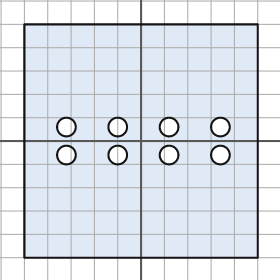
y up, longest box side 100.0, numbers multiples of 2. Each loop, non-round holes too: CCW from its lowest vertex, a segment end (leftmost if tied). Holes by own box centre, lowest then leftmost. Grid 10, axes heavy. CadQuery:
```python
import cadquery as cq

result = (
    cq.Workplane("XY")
    .moveTo(-50.0, -50.0)
    .lineTo(50.0, -50.0)
    .lineTo(50.0, 50.0)
    .lineTo(-50.0, 50.0)
    .close()
    .moveTo(-32.0, -6.0)
    .circle(4.0)
    .moveTo(-10.0, -6.0)
    .circle(4.0)
    .moveTo(12.0, -6.0)
    .circle(4.0)
    .moveTo(34.0, -6.0)
    .circle(4.0)
    .moveTo(-32.0, 6.0)
    .circle(4.0)
    .moveTo(-10.0, 6.0)
    .circle(4.0)
    .moveTo(12.0, 6.0)
    .circle(4.0)
    .moveTo(34.0, 6.0)
    .circle(4.0)
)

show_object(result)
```